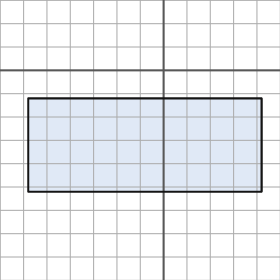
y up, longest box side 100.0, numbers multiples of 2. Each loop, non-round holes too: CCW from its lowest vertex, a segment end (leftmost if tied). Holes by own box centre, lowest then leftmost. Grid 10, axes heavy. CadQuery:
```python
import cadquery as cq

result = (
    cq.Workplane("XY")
    .moveTo(-58.0, -52.0)
    .lineTo(42.0, -52.0)
    .lineTo(42.0, -12.0)
    .lineTo(-58.0, -12.0)
    .close()
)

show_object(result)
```